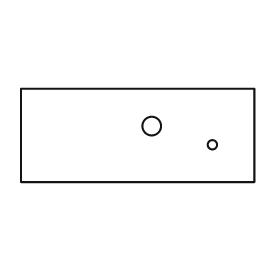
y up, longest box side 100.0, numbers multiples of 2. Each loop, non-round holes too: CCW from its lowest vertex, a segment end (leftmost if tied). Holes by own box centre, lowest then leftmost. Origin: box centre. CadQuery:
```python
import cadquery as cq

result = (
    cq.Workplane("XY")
    .moveTo(-50.0, -20.0)
    .lineTo(50.0, -20.0)
    .lineTo(50.0, 20.0)
    .lineTo(-50.0, 20.0)
    .close()
    .moveTo(32.0, -4.0)
    .circle(2.0)
    .moveTo(6.0, 4.0)
    .circle(4.0)
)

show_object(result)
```